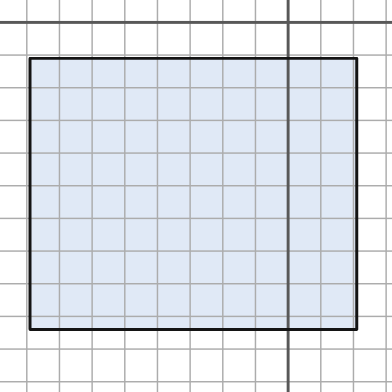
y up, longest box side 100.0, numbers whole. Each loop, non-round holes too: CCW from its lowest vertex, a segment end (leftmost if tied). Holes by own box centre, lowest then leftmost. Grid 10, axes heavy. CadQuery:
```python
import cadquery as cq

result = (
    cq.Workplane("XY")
    .moveTo(-79.0, -94.0)
    .lineTo(21.0, -94.0)
    .lineTo(21.0, -11.0)
    .lineTo(-79.0, -11.0)
    .close()
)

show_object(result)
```